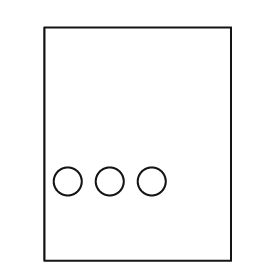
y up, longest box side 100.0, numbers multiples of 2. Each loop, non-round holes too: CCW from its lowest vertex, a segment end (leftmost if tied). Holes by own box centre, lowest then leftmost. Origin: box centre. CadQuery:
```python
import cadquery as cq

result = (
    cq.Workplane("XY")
    .moveTo(-40.0, -50.0)
    .lineTo(40.0, -50.0)
    .lineTo(40.0, 50.0)
    .lineTo(-40.0, 50.0)
    .close()
    .moveTo(-30.0, -16.0)
    .circle(6.0)
    .moveTo(-12.0, -16.0)
    .circle(6.0)
    .moveTo(6.0, -16.0)
    .circle(6.0)
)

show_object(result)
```